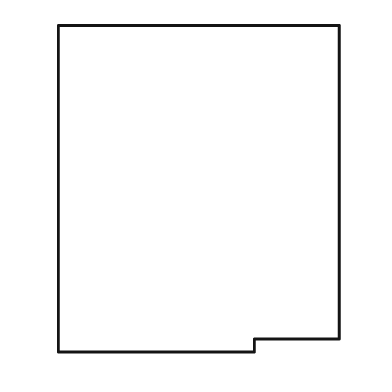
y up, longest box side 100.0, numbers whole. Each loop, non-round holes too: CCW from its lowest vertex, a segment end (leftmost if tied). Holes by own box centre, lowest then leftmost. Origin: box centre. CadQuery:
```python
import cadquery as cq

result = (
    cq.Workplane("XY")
    .moveTo(-43.0, -50.0)
    .lineTo(17.0, -50.0)
    .lineTo(17.0, -46.0)
    .lineTo(43.0, -46.0)
    .lineTo(43.0, 50.0)
    .lineTo(-43.0, 50.0)
    .close()
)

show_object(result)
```